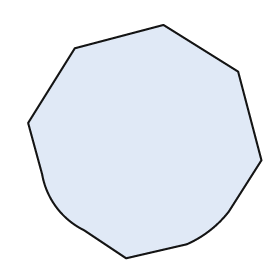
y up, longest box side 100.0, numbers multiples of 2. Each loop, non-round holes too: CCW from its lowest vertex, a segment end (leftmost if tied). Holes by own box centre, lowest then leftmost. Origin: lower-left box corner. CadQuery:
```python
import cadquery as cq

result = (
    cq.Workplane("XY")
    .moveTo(42.0, 0.0)
    .lineTo(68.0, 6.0)
    .threePointArc((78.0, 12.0), (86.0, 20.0))
    .lineTo(100.0, 42.0)
    .lineTo(90.0, 80.0)
    .lineTo(58.0, 100.0)
    .lineTo(20.0, 90.0)
    .lineTo(0.0, 58.0)
    .lineTo(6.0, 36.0)
    .threePointArc((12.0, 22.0), (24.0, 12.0))
    .close()
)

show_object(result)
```